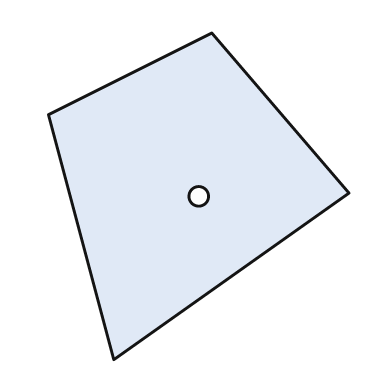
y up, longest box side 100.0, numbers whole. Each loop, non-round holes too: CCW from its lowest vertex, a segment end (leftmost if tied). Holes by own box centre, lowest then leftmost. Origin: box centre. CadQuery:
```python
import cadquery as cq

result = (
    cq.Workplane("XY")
    .moveTo(-26.0, -50.0)
    .lineTo(46.0, 1.0)
    .lineTo(4.0, 50.0)
    .lineTo(-46.0, 25.0)
    .close()
    .moveTo(0.0, 0.0)
    .circle(3.0)
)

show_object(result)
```